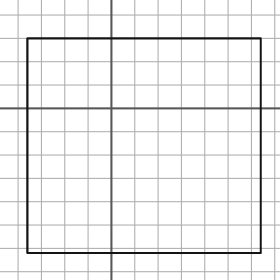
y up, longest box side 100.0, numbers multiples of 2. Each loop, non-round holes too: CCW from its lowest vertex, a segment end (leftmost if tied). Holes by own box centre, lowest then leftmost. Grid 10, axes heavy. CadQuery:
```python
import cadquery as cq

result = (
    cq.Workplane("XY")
    .moveTo(-36.0, -62.0)
    .lineTo(64.0, -62.0)
    .lineTo(64.0, 30.0)
    .lineTo(-36.0, 30.0)
    .close()
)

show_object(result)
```